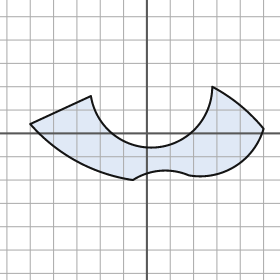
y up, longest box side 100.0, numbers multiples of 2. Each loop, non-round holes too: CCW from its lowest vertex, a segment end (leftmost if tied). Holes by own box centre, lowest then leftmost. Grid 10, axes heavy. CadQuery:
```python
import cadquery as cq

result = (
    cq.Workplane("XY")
    .moveTo(-6.0, -20.0)
    .threePointArc((6.0, -16.0), (18.0, -18.0))
    .threePointArc((38.0, -14.0), (50.0, 2.0))
    .threePointArc((40.0, 12.0), (28.0, 20.0))
    .threePointArc((4.0, -6.0), (-24.0, 16.0))
    .lineTo(-50.0, 4.0)
    .threePointArc((-30.0, -12.0), (-6.0, -20.0))
    .close()
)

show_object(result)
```